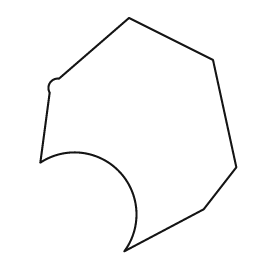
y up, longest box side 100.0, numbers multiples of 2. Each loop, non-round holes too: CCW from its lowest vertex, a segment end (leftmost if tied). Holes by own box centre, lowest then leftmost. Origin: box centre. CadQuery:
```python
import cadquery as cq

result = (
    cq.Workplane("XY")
    .moveTo(-6.0, -50.0)
    .lineTo(28.0, -32.0)
    .lineTo(42.0, -14.0)
    .lineTo(32.0, 32.0)
    .lineTo(-4.0, 50.0)
    .lineTo(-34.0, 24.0)
    .threePointArc((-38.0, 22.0), (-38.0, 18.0))
    .lineTo(-42.0, -12.0)
    .threePointArc((-8.0, -16.0), (-6.0, -50.0))
    .close()
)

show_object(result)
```